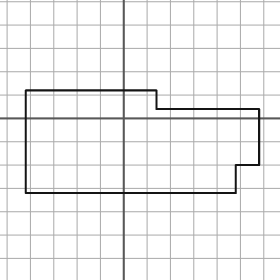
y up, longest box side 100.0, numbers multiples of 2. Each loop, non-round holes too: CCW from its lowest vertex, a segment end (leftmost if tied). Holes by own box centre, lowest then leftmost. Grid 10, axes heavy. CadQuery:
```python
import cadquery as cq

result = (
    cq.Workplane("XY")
    .moveTo(-42.0, -32.0)
    .lineTo(48.0, -32.0)
    .lineTo(48.0, -20.0)
    .lineTo(58.0, -20.0)
    .lineTo(58.0, 4.0)
    .lineTo(14.0, 4.0)
    .lineTo(14.0, 12.0)
    .lineTo(-42.0, 12.0)
    .close()
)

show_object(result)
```